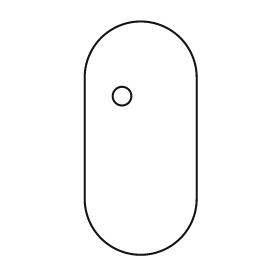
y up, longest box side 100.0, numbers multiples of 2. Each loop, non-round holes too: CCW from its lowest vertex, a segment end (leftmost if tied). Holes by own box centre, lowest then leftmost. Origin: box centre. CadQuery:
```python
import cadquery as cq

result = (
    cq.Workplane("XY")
    .moveTo(-24.0, -26.0)
    .threePointArc((0.0, -50.0), (24.0, -26.0))
    .lineTo(24.0, 26.0)
    .threePointArc((0.0, 50.0), (-24.0, 26.0))
    .close()
    .moveTo(-8.0, 18.0)
    .circle(4.0)
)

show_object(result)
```